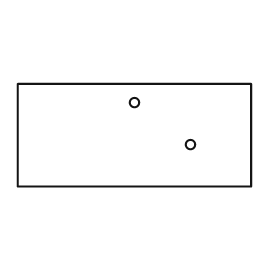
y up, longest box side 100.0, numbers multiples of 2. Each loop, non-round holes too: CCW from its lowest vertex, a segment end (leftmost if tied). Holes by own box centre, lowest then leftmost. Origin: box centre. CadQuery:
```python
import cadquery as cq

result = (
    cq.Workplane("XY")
    .moveTo(-50.0, -22.0)
    .lineTo(50.0, -22.0)
    .lineTo(50.0, 22.0)
    .lineTo(-50.0, 22.0)
    .close()
    .moveTo(24.0, -4.0)
    .circle(2.0)
    .moveTo(0.0, 14.0)
    .circle(2.0)
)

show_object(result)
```